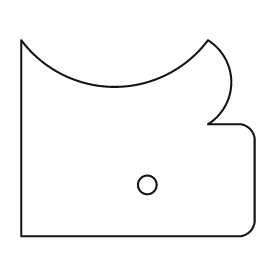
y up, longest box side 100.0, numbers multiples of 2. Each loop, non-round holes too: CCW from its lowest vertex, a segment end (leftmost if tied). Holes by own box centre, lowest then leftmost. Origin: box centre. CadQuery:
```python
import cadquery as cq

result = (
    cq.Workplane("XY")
    .moveTo(-50.0, -42.0)
    .lineTo(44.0, -42.0)
    .threePointArc((48.0, -40.0), (50.0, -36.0))
    .lineTo(50.0, 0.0)
    .threePointArc((48.0, 4.0), (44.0, 6.0))
    .lineTo(30.0, 6.0)
    .threePointArc((40.0, 24.0), (30.0, 42.0))
    .threePointArc((-10.0, 22.0), (-50.0, 42.0))
    .close()
    .moveTo(4.0, -20.0)
    .circle(4.0)
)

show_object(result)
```